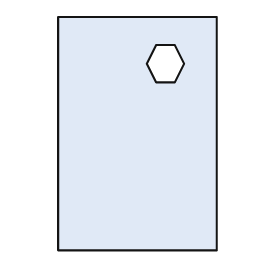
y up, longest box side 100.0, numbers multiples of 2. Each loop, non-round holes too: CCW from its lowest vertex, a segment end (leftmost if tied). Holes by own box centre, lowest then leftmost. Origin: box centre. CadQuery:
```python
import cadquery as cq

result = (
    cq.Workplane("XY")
    .moveTo(-34.0, -50.0)
    .lineTo(34.0, -50.0)
    .lineTo(34.0, 50.0)
    .lineTo(-34.0, 50.0)
    .close()
    .moveTo(8.0, 22.0)
    .lineTo(16.0, 22.0)
    .lineTo(20.0, 30.0)
    .lineTo(16.0, 38.0)
    .lineTo(8.0, 38.0)
    .lineTo(4.0, 30.0)
    .close()
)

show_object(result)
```